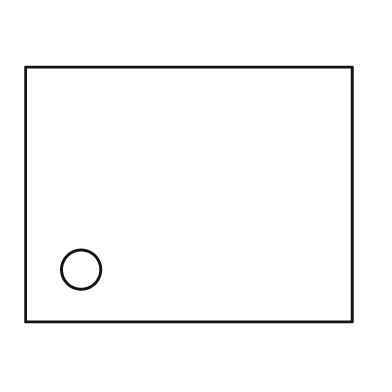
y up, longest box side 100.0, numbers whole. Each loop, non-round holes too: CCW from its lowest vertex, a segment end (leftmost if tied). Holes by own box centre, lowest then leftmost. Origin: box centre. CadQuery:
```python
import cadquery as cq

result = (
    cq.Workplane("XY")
    .moveTo(-50.0, -39.0)
    .lineTo(50.0, -39.0)
    .lineTo(50.0, 39.0)
    .lineTo(-50.0, 39.0)
    .close()
    .moveTo(-33.0, -23.0)
    .circle(6.0)
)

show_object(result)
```